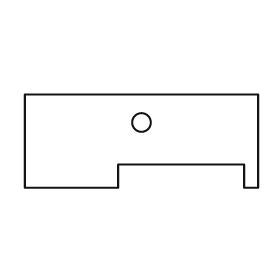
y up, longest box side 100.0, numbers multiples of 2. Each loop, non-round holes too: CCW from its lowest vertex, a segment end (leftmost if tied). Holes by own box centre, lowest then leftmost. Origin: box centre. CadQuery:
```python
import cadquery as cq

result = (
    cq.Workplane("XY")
    .moveTo(-50.0, -20.0)
    .lineTo(-10.0, -20.0)
    .lineTo(-10.0, -10.0)
    .lineTo(44.0, -10.0)
    .lineTo(44.0, -20.0)
    .lineTo(50.0, -20.0)
    .lineTo(50.0, 20.0)
    .lineTo(-50.0, 20.0)
    .close()
    .moveTo(0.0, 8.0)
    .circle(4.0)
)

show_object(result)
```